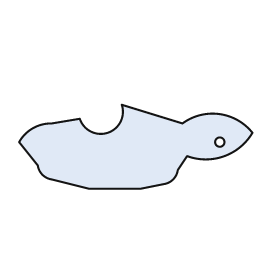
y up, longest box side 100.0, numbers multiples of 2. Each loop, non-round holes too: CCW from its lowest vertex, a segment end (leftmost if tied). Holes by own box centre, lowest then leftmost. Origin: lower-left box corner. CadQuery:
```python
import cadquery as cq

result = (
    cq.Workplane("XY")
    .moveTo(30.0, 0.0)
    .lineTo(52.0, 0.0)
    .lineTo(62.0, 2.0)
    .threePointArc((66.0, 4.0), (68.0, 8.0))
    .lineTo(72.0, 14.0)
    .threePointArc((88.0, 14.0), (100.0, 24.0))
    .threePointArc((86.0, 32.0), (70.0, 28.0))
    .lineTo(44.0, 36.0)
    .threePointArc((38.0, 24.0), (26.0, 30.0))
    .lineTo(14.0, 28.0)
    .threePointArc((6.0, 26.0), (0.0, 20.0))
    .lineTo(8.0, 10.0)
    .threePointArc((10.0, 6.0), (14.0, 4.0))
    .close()
    .moveTo(86.0, 20.0)
    .circle(2.0)
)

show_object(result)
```